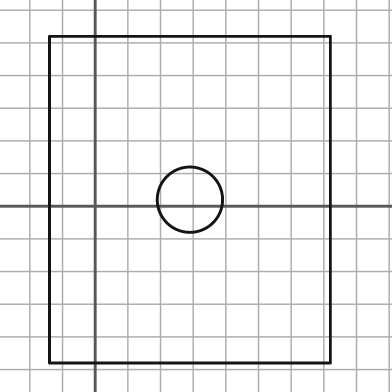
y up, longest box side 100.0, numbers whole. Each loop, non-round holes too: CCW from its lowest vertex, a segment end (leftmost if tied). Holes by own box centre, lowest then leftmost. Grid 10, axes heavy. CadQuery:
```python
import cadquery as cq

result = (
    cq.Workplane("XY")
    .moveTo(-14.0, -48.0)
    .lineTo(72.0, -48.0)
    .lineTo(72.0, 52.0)
    .lineTo(-14.0, 52.0)
    .close()
    .moveTo(29.0, 2.0)
    .circle(10.0)
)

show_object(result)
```